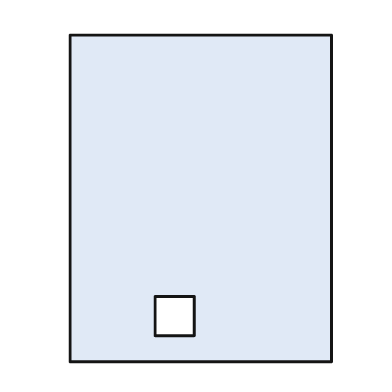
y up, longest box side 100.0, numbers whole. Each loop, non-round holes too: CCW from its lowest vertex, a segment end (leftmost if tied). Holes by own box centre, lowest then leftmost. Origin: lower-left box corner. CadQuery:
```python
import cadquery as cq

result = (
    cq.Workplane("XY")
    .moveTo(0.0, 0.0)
    .lineTo(80.0, 0.0)
    .lineTo(80.0, 100.0)
    .lineTo(0.0, 100.0)
    .close()
    .moveTo(26.0, 8.0)
    .lineTo(38.0, 8.0)
    .lineTo(38.0, 20.0)
    .lineTo(26.0, 20.0)
    .close()
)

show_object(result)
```